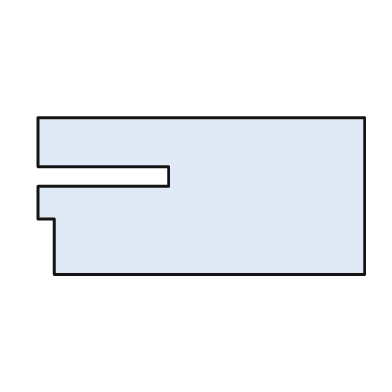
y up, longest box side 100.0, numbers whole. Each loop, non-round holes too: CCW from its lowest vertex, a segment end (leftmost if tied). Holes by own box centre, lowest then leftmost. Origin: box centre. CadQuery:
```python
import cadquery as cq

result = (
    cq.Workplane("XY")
    .moveTo(-45.0, -24.0)
    .lineTo(50.0, -24.0)
    .lineTo(50.0, 24.0)
    .lineTo(-50.0, 24.0)
    .lineTo(-50.0, 9.0)
    .lineTo(-10.0, 9.0)
    .lineTo(-10.0, 3.0)
    .lineTo(-50.0, 3.0)
    .lineTo(-50.0, -7.0)
    .lineTo(-45.0, -7.0)
    .close()
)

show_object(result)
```